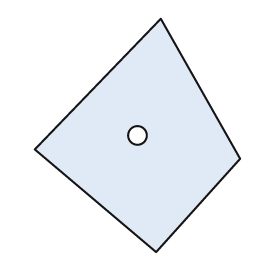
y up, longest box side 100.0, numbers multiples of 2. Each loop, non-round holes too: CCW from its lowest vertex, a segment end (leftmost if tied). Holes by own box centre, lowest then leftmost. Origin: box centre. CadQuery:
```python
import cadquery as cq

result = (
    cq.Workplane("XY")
    .moveTo(8.0, -50.0)
    .lineTo(44.0, -10.0)
    .lineTo(10.0, 50.0)
    .lineTo(-44.0, -6.0)
    .close()
    .moveTo(0.0, 0.0)
    .circle(4.0)
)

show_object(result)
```